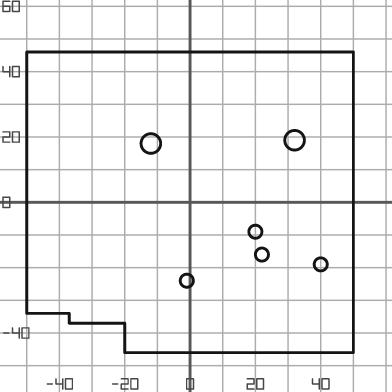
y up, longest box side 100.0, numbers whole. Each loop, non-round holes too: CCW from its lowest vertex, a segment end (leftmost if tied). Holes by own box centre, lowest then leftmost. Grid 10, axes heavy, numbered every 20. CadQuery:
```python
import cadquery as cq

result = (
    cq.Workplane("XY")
    .moveTo(-20.0, -46.0)
    .lineTo(50.0, -46.0)
    .lineTo(50.0, 46.0)
    .lineTo(-50.0, 46.0)
    .lineTo(-50.0, -34.0)
    .lineTo(-37.0, -34.0)
    .lineTo(-37.0, -37.0)
    .lineTo(-20.0, -37.0)
    .close()
    .moveTo(-1.0, -24.0)
    .circle(2.0)
    .moveTo(40.0, -19.0)
    .circle(2.0)
    .moveTo(22.0, -16.0)
    .circle(2.0)
    .moveTo(20.0, -9.0)
    .circle(2.0)
    .moveTo(-12.0, 18.0)
    .circle(3.0)
    .moveTo(32.0, 19.0)
    .circle(3.0)
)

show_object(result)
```